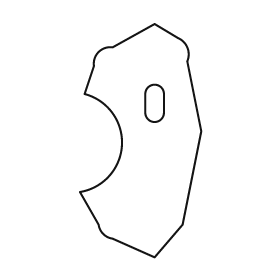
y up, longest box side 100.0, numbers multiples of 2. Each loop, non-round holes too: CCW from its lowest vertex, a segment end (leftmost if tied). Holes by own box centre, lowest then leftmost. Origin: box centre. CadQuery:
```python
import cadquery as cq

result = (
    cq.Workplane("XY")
    .moveTo(6.0, -50.0)
    .lineTo(18.0, -36.0)
    .lineTo(26.0, 4.0)
    .lineTo(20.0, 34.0)
    .threePointArc((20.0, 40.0), (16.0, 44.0))
    .lineTo(6.0, 50.0)
    .lineTo(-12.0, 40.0)
    .threePointArc((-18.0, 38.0), (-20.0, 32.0))
    .lineTo(-24.0, 20.0)
    .threePointArc((-8.0, -2.0), (-26.0, -22.0))
    .lineTo(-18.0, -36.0)
    .threePointArc((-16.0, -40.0), (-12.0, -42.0))
    .close()
    .moveTo(2.0, 12.0)
    .threePointArc((6.0, 8.0), (10.0, 12.0))
    .lineTo(10.0, 20.0)
    .threePointArc((6.0, 24.0), (2.0, 20.0))
    .close()
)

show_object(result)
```